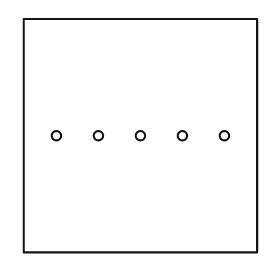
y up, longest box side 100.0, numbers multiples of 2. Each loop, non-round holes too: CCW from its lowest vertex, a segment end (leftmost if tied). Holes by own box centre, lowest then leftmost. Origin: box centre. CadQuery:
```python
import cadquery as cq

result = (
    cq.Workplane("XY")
    .moveTo(-50.0, -50.0)
    .lineTo(50.0, -50.0)
    .lineTo(50.0, 50.0)
    .lineTo(-50.0, 50.0)
    .close()
    .moveTo(-36.0, 0.0)
    .circle(2.0)
    .moveTo(-18.0, 0.0)
    .circle(2.0)
    .moveTo(0.0, 0.0)
    .circle(2.0)
    .moveTo(18.0, 0.0)
    .circle(2.0)
    .moveTo(36.0, 0.0)
    .circle(2.0)
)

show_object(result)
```